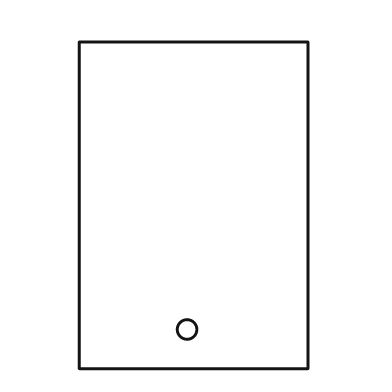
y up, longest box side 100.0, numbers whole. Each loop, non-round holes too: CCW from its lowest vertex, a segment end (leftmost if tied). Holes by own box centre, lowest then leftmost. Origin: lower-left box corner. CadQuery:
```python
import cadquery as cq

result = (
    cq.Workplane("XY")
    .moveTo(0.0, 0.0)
    .lineTo(70.0, 0.0)
    .lineTo(70.0, 100.0)
    .lineTo(0.0, 100.0)
    .close()
    .moveTo(33.0, 12.0)
    .circle(3.0)
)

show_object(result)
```